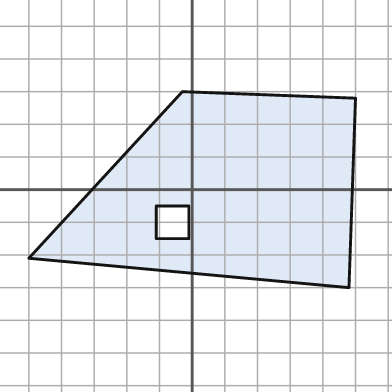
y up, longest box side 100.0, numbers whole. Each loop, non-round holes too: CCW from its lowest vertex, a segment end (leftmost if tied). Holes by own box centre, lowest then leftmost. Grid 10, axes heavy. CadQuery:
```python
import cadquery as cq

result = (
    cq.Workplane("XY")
    .moveTo(48.0, -30.0)
    .lineTo(50.0, 28.0)
    .lineTo(-3.0, 30.0)
    .lineTo(-50.0, -21.0)
    .close()
    .moveTo(-11.0, -15.0)
    .lineTo(-1.0, -15.0)
    .lineTo(-1.0, -5.0)
    .lineTo(-11.0, -5.0)
    .close()
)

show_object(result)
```